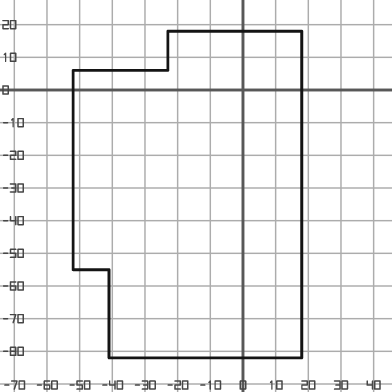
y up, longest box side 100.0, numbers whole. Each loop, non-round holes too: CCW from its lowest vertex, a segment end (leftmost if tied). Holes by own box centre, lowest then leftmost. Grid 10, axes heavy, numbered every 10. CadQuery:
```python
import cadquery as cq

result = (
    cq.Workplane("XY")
    .moveTo(-41.0, -82.0)
    .lineTo(18.0, -82.0)
    .lineTo(18.0, 18.0)
    .lineTo(-23.0, 18.0)
    .lineTo(-23.0, 6.0)
    .lineTo(-52.0, 6.0)
    .lineTo(-52.0, -55.0)
    .lineTo(-41.0, -55.0)
    .close()
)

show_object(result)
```